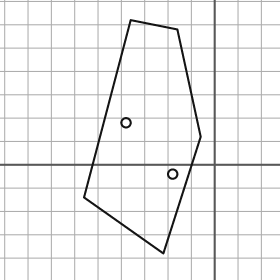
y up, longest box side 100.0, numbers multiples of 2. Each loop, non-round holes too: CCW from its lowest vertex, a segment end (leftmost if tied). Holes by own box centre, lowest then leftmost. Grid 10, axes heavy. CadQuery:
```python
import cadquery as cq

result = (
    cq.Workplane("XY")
    .moveTo(-22.0, -38.0)
    .lineTo(-6.0, 12.0)
    .lineTo(-16.0, 58.0)
    .lineTo(-36.0, 62.0)
    .lineTo(-56.0, -14.0)
    .close()
    .moveTo(-18.0, -4.0)
    .circle(2.0)
    .moveTo(-38.0, 18.0)
    .circle(2.0)
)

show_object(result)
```